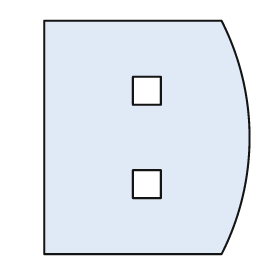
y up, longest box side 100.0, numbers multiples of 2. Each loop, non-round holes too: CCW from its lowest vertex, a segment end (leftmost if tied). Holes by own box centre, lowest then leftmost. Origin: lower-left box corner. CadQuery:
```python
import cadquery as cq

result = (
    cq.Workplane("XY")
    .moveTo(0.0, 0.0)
    .lineTo(76.0, 0.0)
    .threePointArc((88.0, 50.0), (76.0, 100.0))
    .lineTo(0.0, 100.0)
    .close()
    .moveTo(38.0, 24.0)
    .lineTo(50.0, 24.0)
    .lineTo(50.0, 36.0)
    .lineTo(38.0, 36.0)
    .close()
    .moveTo(38.0, 64.0)
    .lineTo(50.0, 64.0)
    .lineTo(50.0, 76.0)
    .lineTo(38.0, 76.0)
    .close()
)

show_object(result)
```